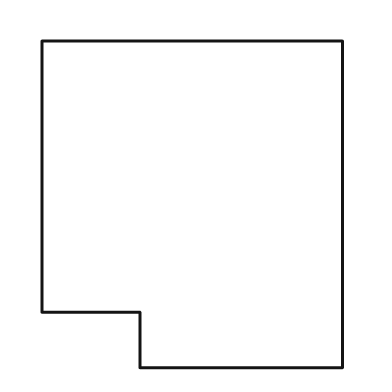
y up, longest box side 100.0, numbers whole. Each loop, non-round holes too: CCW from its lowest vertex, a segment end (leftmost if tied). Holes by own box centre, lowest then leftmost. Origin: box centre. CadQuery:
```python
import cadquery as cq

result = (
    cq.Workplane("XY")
    .moveTo(-16.0, -50.0)
    .lineTo(46.0, -50.0)
    .lineTo(46.0, 50.0)
    .lineTo(-46.0, 50.0)
    .lineTo(-46.0, -33.0)
    .lineTo(-16.0, -33.0)
    .close()
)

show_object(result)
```